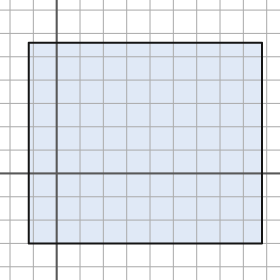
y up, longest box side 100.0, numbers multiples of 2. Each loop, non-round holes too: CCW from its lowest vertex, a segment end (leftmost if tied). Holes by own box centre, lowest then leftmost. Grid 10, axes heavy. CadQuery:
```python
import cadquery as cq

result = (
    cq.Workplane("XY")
    .moveTo(-12.0, -30.0)
    .lineTo(88.0, -30.0)
    .lineTo(88.0, 56.0)
    .lineTo(-12.0, 56.0)
    .close()
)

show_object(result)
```